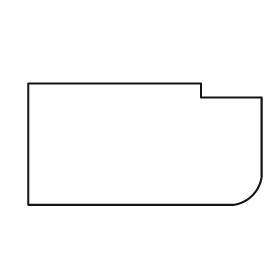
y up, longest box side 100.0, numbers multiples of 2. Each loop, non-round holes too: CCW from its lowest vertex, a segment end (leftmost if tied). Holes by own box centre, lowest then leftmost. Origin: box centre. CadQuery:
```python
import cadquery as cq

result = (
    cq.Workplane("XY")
    .moveTo(-50.0, -26.0)
    .lineTo(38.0, -26.0)
    .threePointArc((46.0, -22.0), (50.0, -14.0))
    .lineTo(50.0, 20.0)
    .lineTo(24.0, 20.0)
    .lineTo(24.0, 26.0)
    .lineTo(-50.0, 26.0)
    .close()
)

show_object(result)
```